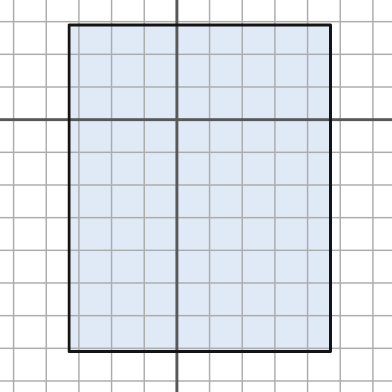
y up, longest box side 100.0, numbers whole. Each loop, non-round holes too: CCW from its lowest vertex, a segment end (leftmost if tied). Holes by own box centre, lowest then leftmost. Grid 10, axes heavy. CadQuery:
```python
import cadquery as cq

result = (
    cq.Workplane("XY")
    .moveTo(-33.0, -71.0)
    .lineTo(47.0, -71.0)
    .lineTo(47.0, 29.0)
    .lineTo(-33.0, 29.0)
    .close()
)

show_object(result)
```